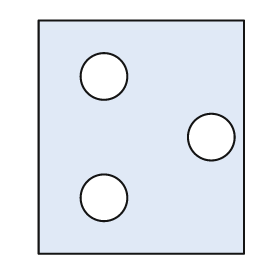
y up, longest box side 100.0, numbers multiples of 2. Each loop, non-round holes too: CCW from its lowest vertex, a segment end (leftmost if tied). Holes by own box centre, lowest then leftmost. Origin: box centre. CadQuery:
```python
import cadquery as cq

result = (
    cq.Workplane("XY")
    .moveTo(-44.0, -50.0)
    .lineTo(44.0, -50.0)
    .lineTo(44.0, 50.0)
    .lineTo(-44.0, 50.0)
    .close()
    .moveTo(-16.0, -26.0)
    .circle(10.0)
    .moveTo(30.0, 0.0)
    .circle(10.0)
    .moveTo(-16.0, 26.0)
    .circle(10.0)
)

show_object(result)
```